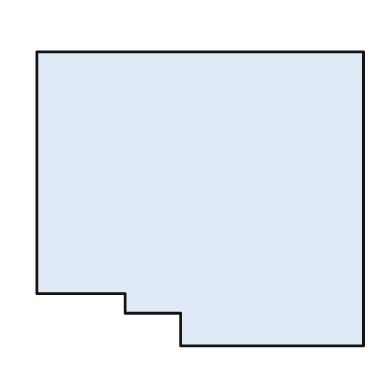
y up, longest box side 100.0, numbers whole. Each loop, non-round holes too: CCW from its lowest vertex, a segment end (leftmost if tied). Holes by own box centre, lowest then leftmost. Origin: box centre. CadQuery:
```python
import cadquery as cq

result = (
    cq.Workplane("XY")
    .moveTo(-6.0, -45.0)
    .lineTo(50.0, -45.0)
    .lineTo(50.0, 45.0)
    .lineTo(-50.0, 45.0)
    .lineTo(-50.0, -29.0)
    .lineTo(-23.0, -29.0)
    .lineTo(-23.0, -35.0)
    .lineTo(-6.0, -35.0)
    .close()
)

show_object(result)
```